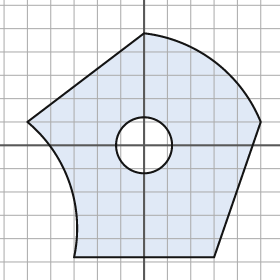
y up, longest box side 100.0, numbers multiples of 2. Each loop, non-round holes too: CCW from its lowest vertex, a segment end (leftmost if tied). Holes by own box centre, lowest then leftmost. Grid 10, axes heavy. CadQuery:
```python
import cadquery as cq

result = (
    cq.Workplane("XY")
    .moveTo(-30.0, -48.0)
    .lineTo(30.0, -48.0)
    .lineTo(50.0, 10.0)
    .threePointArc((30.0, 36.0), (0.0, 48.0))
    .lineTo(-50.0, 10.0)
    .threePointArc((-32.0, -16.0), (-30.0, -48.0))
    .close()
    .moveTo(0.0, 0.0)
    .circle(12.0)
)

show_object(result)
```